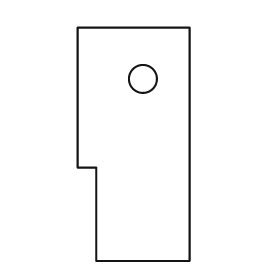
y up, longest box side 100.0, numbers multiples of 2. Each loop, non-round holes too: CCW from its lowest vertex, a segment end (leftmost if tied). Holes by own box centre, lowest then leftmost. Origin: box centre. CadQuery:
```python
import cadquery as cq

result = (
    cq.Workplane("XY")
    .moveTo(-16.0, -50.0)
    .lineTo(24.0, -50.0)
    .lineTo(24.0, 50.0)
    .lineTo(-24.0, 50.0)
    .lineTo(-24.0, -10.0)
    .lineTo(-16.0, -10.0)
    .close()
    .moveTo(4.0, 28.0)
    .circle(6.0)
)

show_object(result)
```